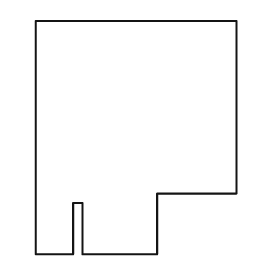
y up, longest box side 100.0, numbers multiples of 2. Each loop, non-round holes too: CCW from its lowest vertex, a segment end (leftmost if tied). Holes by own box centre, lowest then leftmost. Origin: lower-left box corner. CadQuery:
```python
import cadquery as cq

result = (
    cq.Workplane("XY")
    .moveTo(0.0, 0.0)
    .lineTo(16.0, 0.0)
    .lineTo(16.0, 22.0)
    .lineTo(20.0, 22.0)
    .lineTo(20.0, 0.0)
    .lineTo(52.0, 0.0)
    .lineTo(52.0, 26.0)
    .lineTo(86.0, 26.0)
    .lineTo(86.0, 100.0)
    .lineTo(0.0, 100.0)
    .close()
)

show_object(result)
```